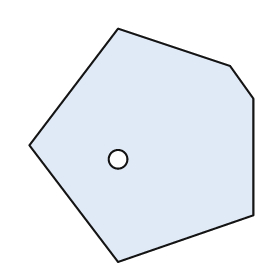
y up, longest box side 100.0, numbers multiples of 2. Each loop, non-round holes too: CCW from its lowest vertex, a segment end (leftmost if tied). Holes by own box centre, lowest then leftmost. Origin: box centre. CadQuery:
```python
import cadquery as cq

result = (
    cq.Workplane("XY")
    .moveTo(-10.0, -50.0)
    .lineTo(48.0, -30.0)
    .lineTo(48.0, 20.0)
    .lineTo(38.0, 34.0)
    .lineTo(-10.0, 50.0)
    .lineTo(-48.0, 0.0)
    .close()
    .moveTo(-10.0, -6.0)
    .circle(4.0)
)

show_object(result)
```